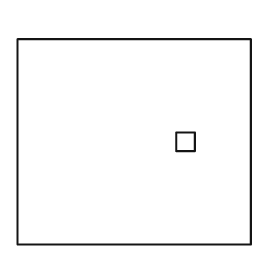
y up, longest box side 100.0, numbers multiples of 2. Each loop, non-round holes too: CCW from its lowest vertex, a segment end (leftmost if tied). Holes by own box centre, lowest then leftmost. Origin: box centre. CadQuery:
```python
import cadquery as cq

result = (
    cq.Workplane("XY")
    .moveTo(-50.0, -44.0)
    .lineTo(50.0, -44.0)
    .lineTo(50.0, 44.0)
    .lineTo(-50.0, 44.0)
    .close()
    .moveTo(18.0, -4.0)
    .lineTo(26.0, -4.0)
    .lineTo(26.0, 4.0)
    .lineTo(18.0, 4.0)
    .close()
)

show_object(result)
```